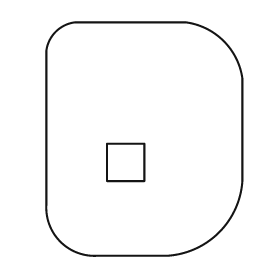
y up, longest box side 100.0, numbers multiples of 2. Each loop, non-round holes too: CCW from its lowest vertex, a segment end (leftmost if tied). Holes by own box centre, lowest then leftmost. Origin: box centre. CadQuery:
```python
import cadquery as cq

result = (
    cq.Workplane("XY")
    .moveTo(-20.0, -50.0)
    .lineTo(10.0, -50.0)
    .threePointArc((32.0, -40.0), (42.0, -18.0))
    .lineTo(42.0, 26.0)
    .threePointArc((34.0, 42.0), (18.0, 50.0))
    .lineTo(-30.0, 50.0)
    .threePointArc((-38.0, 46.0), (-42.0, 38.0))
    .lineTo(-42.0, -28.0)
    .threePointArc((-36.0, -44.0), (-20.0, -50.0))
    .close()
    .moveTo(-16.0, -18.0)
    .lineTo(0.0, -18.0)
    .lineTo(0.0, -2.0)
    .lineTo(-16.0, -2.0)
    .close()
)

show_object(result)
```